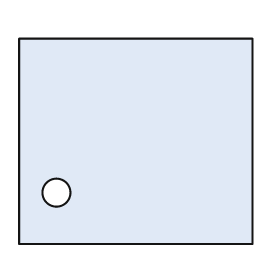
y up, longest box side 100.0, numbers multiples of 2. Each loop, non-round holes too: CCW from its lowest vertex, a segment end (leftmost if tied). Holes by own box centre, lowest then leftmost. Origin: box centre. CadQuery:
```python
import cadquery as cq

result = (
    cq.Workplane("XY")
    .moveTo(-50.0, -44.0)
    .lineTo(50.0, -44.0)
    .lineTo(50.0, 44.0)
    .lineTo(-50.0, 44.0)
    .close()
    .moveTo(-34.0, -22.0)
    .circle(6.0)
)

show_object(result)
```